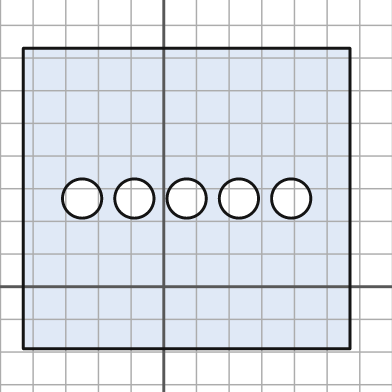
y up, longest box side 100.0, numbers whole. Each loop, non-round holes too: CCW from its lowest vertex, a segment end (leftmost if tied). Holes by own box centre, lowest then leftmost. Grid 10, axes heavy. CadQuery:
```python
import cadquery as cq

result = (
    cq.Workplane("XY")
    .moveTo(-43.0, -19.0)
    .lineTo(57.0, -19.0)
    .lineTo(57.0, 73.0)
    .lineTo(-43.0, 73.0)
    .close()
    .moveTo(-25.0, 27.0)
    .circle(6.0)
    .moveTo(-9.0, 27.0)
    .circle(6.0)
    .moveTo(7.0, 27.0)
    .circle(6.0)
    .moveTo(23.0, 27.0)
    .circle(6.0)
    .moveTo(39.0, 27.0)
    .circle(6.0)
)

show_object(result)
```